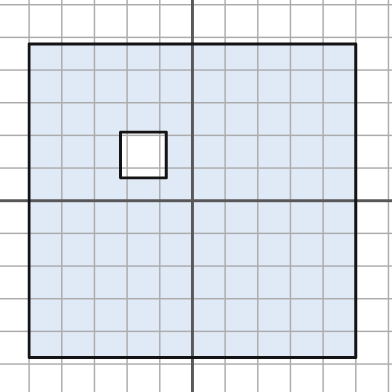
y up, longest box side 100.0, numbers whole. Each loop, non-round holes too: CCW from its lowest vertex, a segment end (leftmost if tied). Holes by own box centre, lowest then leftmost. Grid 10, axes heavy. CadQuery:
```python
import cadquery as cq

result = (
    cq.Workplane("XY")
    .moveTo(-50.0, -48.0)
    .lineTo(50.0, -48.0)
    .lineTo(50.0, 48.0)
    .lineTo(-50.0, 48.0)
    .close()
    .moveTo(-22.0, 7.0)
    .lineTo(-8.0, 7.0)
    .lineTo(-8.0, 21.0)
    .lineTo(-22.0, 21.0)
    .close()
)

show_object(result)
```